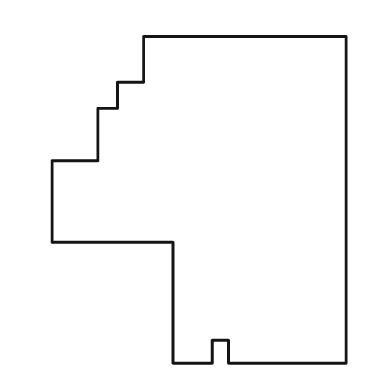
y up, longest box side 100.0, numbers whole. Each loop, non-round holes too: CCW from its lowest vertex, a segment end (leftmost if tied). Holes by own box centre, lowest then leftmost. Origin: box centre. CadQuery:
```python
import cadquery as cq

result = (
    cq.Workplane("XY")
    .moveTo(-8.0, -50.0)
    .lineTo(4.0, -50.0)
    .lineTo(4.0, -43.0)
    .lineTo(9.0, -43.0)
    .lineTo(9.0, -50.0)
    .lineTo(45.0, -50.0)
    .lineTo(45.0, 50.0)
    .lineTo(-17.0, 50.0)
    .lineTo(-17.0, 36.0)
    .lineTo(-25.0, 36.0)
    .lineTo(-25.0, 28.0)
    .lineTo(-31.0, 28.0)
    .lineTo(-31.0, 12.0)
    .lineTo(-45.0, 12.0)
    .lineTo(-45.0, -13.0)
    .lineTo(-8.0, -13.0)
    .close()
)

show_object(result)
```